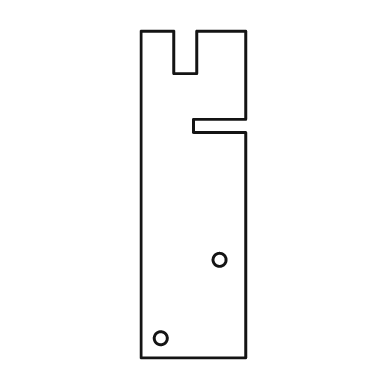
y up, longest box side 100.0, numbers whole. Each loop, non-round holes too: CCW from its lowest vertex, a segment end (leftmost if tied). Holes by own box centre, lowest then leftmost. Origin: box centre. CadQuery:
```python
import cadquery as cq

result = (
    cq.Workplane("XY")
    .moveTo(-16.0, -50.0)
    .lineTo(16.0, -50.0)
    .lineTo(16.0, 19.0)
    .lineTo(0.0, 19.0)
    .lineTo(0.0, 23.0)
    .lineTo(16.0, 23.0)
    .lineTo(16.0, 50.0)
    .lineTo(1.0, 50.0)
    .lineTo(1.0, 37.0)
    .lineTo(-6.0, 37.0)
    .lineTo(-6.0, 50.0)
    .lineTo(-16.0, 50.0)
    .close()
    .moveTo(-10.0, -44.0)
    .circle(2.0)
    .moveTo(8.0, -20.0)
    .circle(2.0)
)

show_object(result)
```